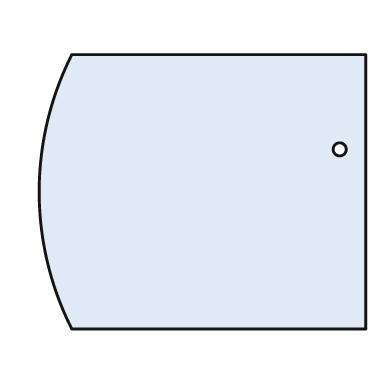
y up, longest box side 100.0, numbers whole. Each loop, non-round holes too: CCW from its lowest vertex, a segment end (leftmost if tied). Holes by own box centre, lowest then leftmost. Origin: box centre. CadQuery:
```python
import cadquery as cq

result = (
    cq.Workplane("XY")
    .moveTo(-40.0, -42.0)
    .lineTo(50.0, -42.0)
    .lineTo(50.0, 42.0)
    .lineTo(-40.0, 42.0)
    .threePointArc((-50.0, 0.0), (-40.0, -42.0))
    .close()
    .moveTo(42.0, 13.0)
    .circle(2.0)
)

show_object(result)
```